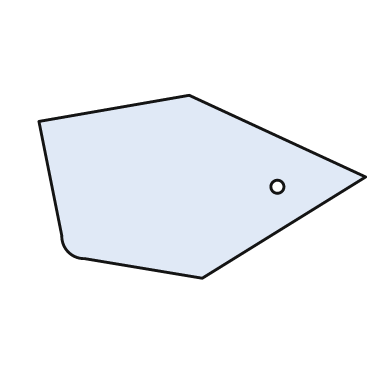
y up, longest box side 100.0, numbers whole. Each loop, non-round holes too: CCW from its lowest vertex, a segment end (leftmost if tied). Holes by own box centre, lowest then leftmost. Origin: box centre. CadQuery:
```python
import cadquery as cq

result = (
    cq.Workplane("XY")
    .moveTo(0.0, -28.0)
    .lineTo(50.0, 3.0)
    .lineTo(-4.0, 28.0)
    .lineTo(-50.0, 20.0)
    .lineTo(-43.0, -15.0)
    .threePointArc((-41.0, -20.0), (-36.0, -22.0))
    .close()
    .moveTo(23.0, 0.0)
    .circle(2.0)
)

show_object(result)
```